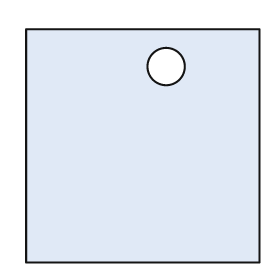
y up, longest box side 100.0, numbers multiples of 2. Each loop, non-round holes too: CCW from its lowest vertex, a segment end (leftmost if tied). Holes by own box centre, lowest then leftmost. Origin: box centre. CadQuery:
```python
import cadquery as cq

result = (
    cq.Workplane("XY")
    .moveTo(-50.0, -50.0)
    .lineTo(50.0, -50.0)
    .lineTo(50.0, 50.0)
    .lineTo(-50.0, 50.0)
    .close()
    .moveTo(10.0, 34.0)
    .circle(8.0)
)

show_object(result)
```